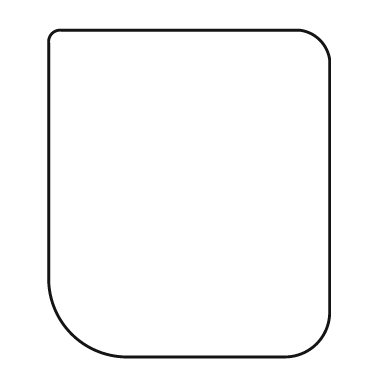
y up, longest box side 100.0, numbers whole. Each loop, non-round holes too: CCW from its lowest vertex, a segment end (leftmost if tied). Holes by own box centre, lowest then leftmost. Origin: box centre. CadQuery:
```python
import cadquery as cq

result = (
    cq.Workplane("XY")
    .moveTo(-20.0, -50.0)
    .lineTo(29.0, -50.0)
    .threePointArc((39.0, -46.0), (43.0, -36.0))
    .lineTo(43.0, 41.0)
    .threePointArc((40.0, 47.0), (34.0, 50.0))
    .lineTo(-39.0, 50.0)
    .threePointArc((-42.0, 49.0), (-43.0, 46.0))
    .lineTo(-43.0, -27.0)
    .threePointArc((-36.0, -43.0), (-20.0, -50.0))
    .close()
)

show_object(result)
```